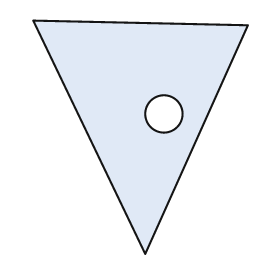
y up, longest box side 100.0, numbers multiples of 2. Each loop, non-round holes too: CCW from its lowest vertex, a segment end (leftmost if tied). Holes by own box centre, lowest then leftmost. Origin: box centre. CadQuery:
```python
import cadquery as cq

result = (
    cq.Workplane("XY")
    .moveTo(2.0, -50.0)
    .lineTo(46.0, 48.0)
    .lineTo(-46.0, 50.0)
    .close()
    .moveTo(10.0, 10.0)
    .circle(8.0)
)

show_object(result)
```